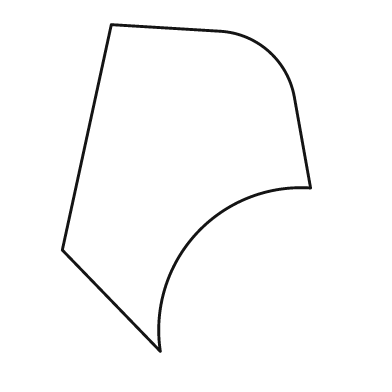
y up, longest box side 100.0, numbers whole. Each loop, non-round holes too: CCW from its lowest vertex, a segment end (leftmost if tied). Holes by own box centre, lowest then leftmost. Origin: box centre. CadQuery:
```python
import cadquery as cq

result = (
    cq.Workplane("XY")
    .moveTo(-8.0, -50.0)
    .threePointArc((3.0, -14.0), (38.0, 0.0))
    .lineTo(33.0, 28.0)
    .threePointArc((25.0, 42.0), (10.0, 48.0))
    .lineTo(-23.0, 50.0)
    .lineTo(-38.0, -19.0)
    .close()
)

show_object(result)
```